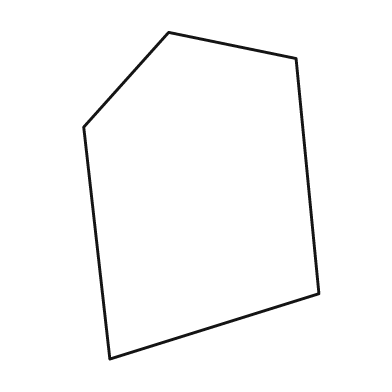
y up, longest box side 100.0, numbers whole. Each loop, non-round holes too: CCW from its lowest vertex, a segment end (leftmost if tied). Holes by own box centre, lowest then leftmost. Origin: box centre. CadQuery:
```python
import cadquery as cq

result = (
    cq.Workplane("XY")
    .moveTo(-28.0, -50.0)
    .lineTo(36.0, -30.0)
    .lineTo(29.0, 42.0)
    .lineTo(-10.0, 50.0)
    .lineTo(-36.0, 21.0)
    .close()
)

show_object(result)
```